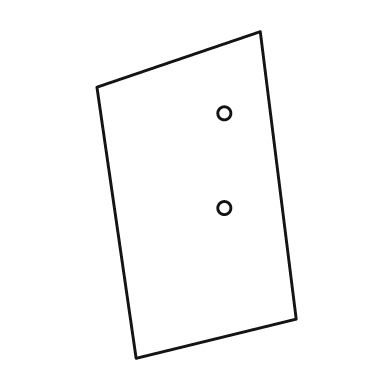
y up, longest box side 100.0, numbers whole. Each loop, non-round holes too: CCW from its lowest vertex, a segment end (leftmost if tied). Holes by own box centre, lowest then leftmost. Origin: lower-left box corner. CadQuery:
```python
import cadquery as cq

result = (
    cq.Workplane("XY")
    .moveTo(12.0, 0.0)
    .lineTo(61.0, 12.0)
    .lineTo(50.0, 100.0)
    .lineTo(0.0, 83.0)
    .close()
    .moveTo(39.0, 46.0)
    .circle(2.0)
    .moveTo(39.0, 75.0)
    .circle(2.0)
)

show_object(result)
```